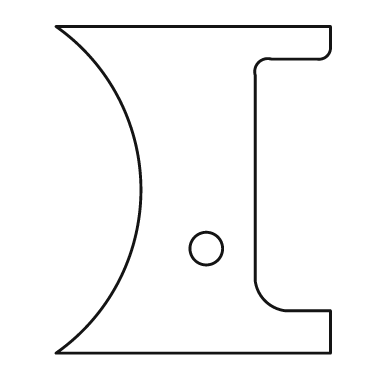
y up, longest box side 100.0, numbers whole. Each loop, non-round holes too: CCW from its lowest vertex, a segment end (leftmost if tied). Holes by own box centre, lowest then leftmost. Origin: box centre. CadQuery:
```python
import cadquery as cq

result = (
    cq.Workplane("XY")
    .moveTo(-42.0, -50.0)
    .lineTo(42.0, -50.0)
    .lineTo(42.0, -37.0)
    .lineTo(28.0, -37.0)
    .threePointArc((22.0, -34.0), (19.0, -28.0))
    .lineTo(19.0, 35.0)
    .threePointArc((20.0, 39.0), (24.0, 40.0))
    .lineTo(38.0, 40.0)
    .threePointArc((41.0, 41.0), (42.0, 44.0))
    .lineTo(42.0, 50.0)
    .lineTo(-42.0, 50.0)
    .threePointArc((-16.0, 0.0), (-42.0, -50.0))
    .close()
    .moveTo(4.0, -18.0)
    .circle(5.0)
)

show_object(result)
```